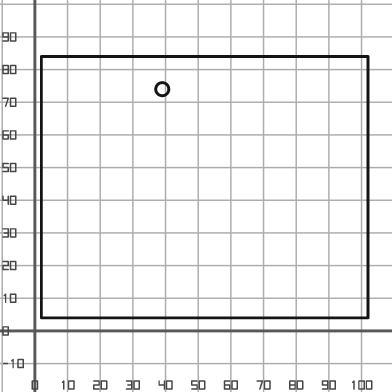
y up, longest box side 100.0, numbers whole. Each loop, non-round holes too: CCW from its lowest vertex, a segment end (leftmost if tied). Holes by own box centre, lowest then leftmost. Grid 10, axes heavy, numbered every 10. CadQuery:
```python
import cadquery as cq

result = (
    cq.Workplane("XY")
    .moveTo(2.0, 4.0)
    .lineTo(102.0, 4.0)
    .lineTo(102.0, 84.0)
    .lineTo(2.0, 84.0)
    .close()
    .moveTo(39.0, 74.0)
    .circle(2.0)
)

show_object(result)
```